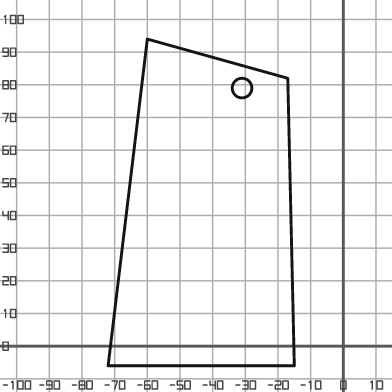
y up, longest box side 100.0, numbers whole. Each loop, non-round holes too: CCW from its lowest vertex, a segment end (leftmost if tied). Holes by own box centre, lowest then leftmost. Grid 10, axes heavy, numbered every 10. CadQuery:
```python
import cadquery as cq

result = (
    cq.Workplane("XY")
    .moveTo(-72.0, -6.0)
    .lineTo(-15.0, -6.0)
    .lineTo(-17.0, 82.0)
    .lineTo(-60.0, 94.0)
    .close()
    .moveTo(-31.0, 79.0)
    .circle(3.0)
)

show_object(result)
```